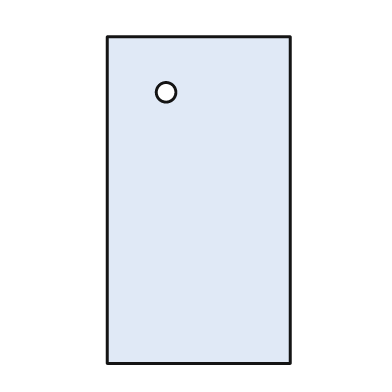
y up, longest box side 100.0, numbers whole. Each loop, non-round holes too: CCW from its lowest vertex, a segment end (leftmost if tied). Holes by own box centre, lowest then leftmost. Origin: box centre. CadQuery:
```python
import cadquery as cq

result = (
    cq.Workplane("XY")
    .moveTo(-28.0, -50.0)
    .lineTo(28.0, -50.0)
    .lineTo(28.0, 50.0)
    .lineTo(-28.0, 50.0)
    .close()
    .moveTo(-10.0, 33.0)
    .circle(3.0)
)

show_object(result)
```